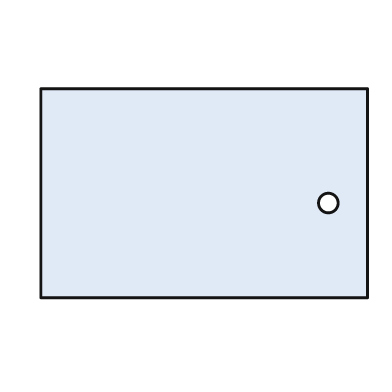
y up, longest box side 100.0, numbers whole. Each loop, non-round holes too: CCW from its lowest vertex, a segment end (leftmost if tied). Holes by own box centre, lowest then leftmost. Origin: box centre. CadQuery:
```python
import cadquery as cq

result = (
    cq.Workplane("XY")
    .moveTo(-50.0, -32.0)
    .lineTo(50.0, -32.0)
    .lineTo(50.0, 32.0)
    .lineTo(-50.0, 32.0)
    .close()
    .moveTo(38.0, -3.0)
    .circle(3.0)
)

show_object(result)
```